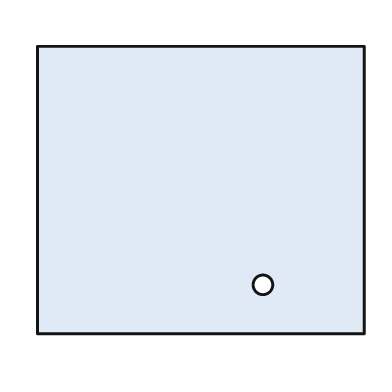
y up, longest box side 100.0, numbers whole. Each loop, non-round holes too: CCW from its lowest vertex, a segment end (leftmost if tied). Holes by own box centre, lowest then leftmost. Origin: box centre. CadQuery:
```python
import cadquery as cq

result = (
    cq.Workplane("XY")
    .moveTo(-50.0, -44.0)
    .lineTo(50.0, -44.0)
    .lineTo(50.0, 44.0)
    .lineTo(-50.0, 44.0)
    .close()
    .moveTo(19.0, -29.0)
    .circle(3.0)
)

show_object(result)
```